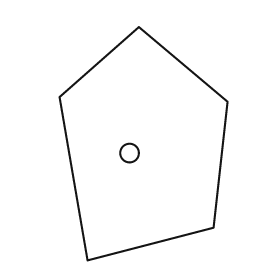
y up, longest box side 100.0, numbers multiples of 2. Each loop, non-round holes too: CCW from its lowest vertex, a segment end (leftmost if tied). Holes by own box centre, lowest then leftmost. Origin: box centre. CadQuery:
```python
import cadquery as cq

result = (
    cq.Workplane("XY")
    .moveTo(-24.0, -50.0)
    .lineTo(30.0, -36.0)
    .lineTo(36.0, 18.0)
    .lineTo(-2.0, 50.0)
    .lineTo(-36.0, 20.0)
    .close()
    .moveTo(-6.0, -4.0)
    .circle(4.0)
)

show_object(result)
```